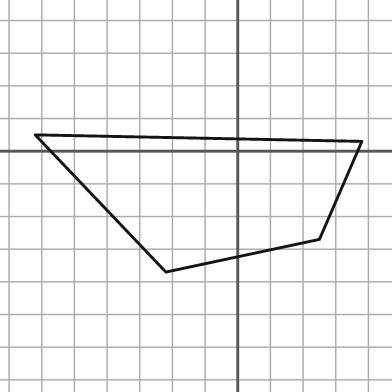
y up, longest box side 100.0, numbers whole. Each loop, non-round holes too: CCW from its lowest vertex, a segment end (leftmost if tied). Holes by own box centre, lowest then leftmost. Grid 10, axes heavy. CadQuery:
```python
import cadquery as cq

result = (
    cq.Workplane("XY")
    .moveTo(-22.0, -37.0)
    .lineTo(25.0, -27.0)
    .lineTo(38.0, 3.0)
    .lineTo(-62.0, 5.0)
    .close()
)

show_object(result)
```